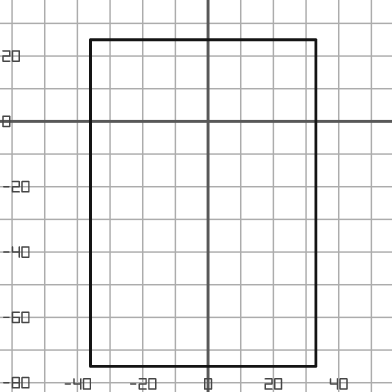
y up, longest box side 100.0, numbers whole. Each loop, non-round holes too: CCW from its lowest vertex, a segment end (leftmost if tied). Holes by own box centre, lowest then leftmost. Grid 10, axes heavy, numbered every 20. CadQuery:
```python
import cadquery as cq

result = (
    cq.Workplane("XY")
    .moveTo(-36.0, -75.0)
    .lineTo(33.0, -75.0)
    .lineTo(33.0, 25.0)
    .lineTo(-36.0, 25.0)
    .close()
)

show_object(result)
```